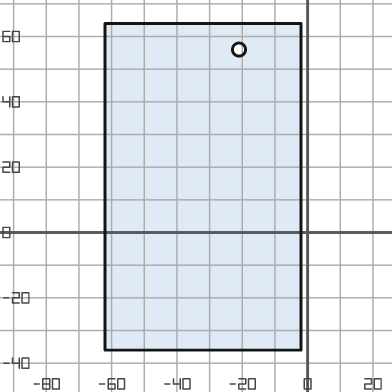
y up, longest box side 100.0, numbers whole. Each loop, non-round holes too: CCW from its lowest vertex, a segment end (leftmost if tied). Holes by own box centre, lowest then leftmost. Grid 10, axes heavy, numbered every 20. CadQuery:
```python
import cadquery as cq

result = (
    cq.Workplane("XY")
    .moveTo(-62.0, -36.0)
    .lineTo(-2.0, -36.0)
    .lineTo(-2.0, 64.0)
    .lineTo(-62.0, 64.0)
    .close()
    .moveTo(-21.0, 56.0)
    .circle(2.0)
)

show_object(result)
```